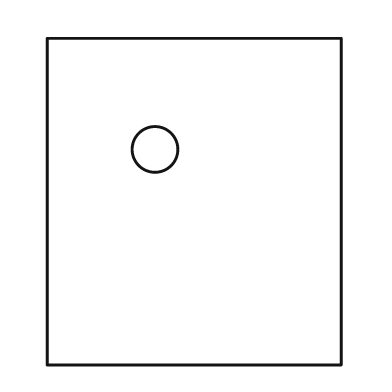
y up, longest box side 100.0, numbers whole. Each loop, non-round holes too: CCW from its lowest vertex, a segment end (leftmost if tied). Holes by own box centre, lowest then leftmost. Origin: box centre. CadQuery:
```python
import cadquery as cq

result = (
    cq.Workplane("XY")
    .moveTo(-45.0, -50.0)
    .lineTo(45.0, -50.0)
    .lineTo(45.0, 50.0)
    .lineTo(-45.0, 50.0)
    .close()
    .moveTo(-12.0, 16.0)
    .circle(7.0)
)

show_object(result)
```